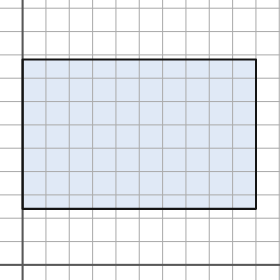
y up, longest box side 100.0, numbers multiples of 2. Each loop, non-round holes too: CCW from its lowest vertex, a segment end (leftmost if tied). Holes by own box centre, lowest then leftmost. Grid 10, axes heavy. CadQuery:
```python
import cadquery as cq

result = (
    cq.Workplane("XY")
    .moveTo(0.0, 24.0)
    .lineTo(100.0, 24.0)
    .lineTo(100.0, 88.0)
    .lineTo(0.0, 88.0)
    .close()
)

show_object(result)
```